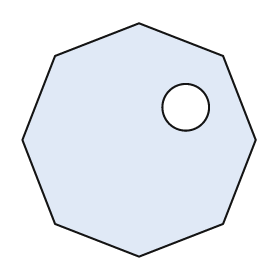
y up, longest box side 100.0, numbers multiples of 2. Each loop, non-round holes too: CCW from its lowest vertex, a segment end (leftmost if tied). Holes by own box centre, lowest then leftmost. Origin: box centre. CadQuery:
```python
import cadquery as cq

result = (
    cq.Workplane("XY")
    .moveTo(0.0, -50.0)
    .lineTo(36.0, -36.0)
    .lineTo(50.0, 0.0)
    .lineTo(36.0, 36.0)
    .lineTo(0.0, 50.0)
    .lineTo(-36.0, 36.0)
    .lineTo(-50.0, 0.0)
    .lineTo(-36.0, -36.0)
    .close()
    .moveTo(20.0, 14.0)
    .circle(10.0)
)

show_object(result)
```